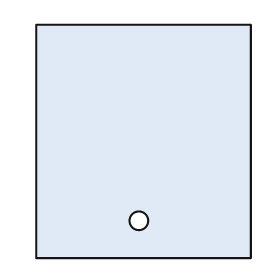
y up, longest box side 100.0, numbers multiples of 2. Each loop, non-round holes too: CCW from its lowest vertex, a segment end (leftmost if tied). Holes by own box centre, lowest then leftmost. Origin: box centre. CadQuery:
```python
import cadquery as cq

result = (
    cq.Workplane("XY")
    .moveTo(-46.0, -50.0)
    .lineTo(46.0, -50.0)
    .lineTo(46.0, 50.0)
    .lineTo(-46.0, 50.0)
    .close()
    .moveTo(-2.0, -34.0)
    .circle(4.0)
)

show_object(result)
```